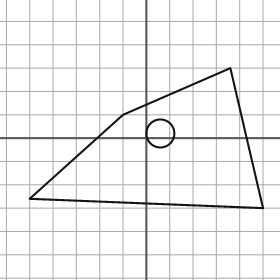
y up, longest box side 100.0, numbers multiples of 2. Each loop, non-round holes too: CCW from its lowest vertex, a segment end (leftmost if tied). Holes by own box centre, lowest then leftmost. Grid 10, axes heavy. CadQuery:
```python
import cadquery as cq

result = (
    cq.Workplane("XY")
    .moveTo(50.0, -30.0)
    .lineTo(36.0, 30.0)
    .lineTo(-10.0, 10.0)
    .lineTo(-50.0, -26.0)
    .close()
    .moveTo(6.0, 2.0)
    .circle(6.0)
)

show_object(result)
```